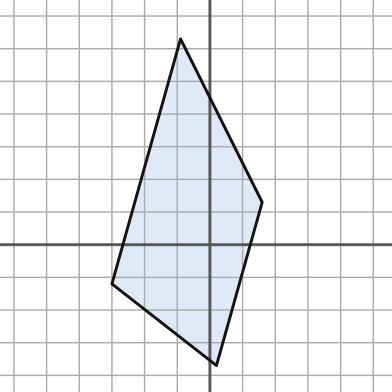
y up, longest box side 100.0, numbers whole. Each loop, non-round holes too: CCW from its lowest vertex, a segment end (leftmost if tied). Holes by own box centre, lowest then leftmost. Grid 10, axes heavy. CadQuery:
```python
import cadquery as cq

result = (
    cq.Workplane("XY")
    .moveTo(2.0, -37.0)
    .lineTo(16.0, 13.0)
    .lineTo(-9.0, 63.0)
    .lineTo(-30.0, -12.0)
    .close()
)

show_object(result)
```